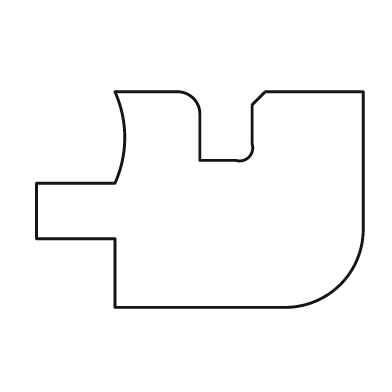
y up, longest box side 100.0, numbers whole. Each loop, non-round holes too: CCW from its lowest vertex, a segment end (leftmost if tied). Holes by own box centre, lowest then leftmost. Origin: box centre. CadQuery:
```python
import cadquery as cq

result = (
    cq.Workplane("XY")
    .moveTo(-26.0, -33.0)
    .lineTo(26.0, -33.0)
    .threePointArc((43.0, -26.0), (50.0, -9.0))
    .lineTo(50.0, 33.0)
    .lineTo(20.0, 33.0)
    .lineTo(16.0, 29.0)
    .lineTo(16.0, 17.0)
    .threePointArc((15.0, 13.0), (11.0, 12.0))
    .lineTo(0.0, 12.0)
    .lineTo(0.0, 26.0)
    .threePointArc((-2.0, 31.0), (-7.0, 33.0))
    .lineTo(-26.0, 33.0)
    .threePointArc((-23.0, 19.0), (-26.0, 5.0))
    .lineTo(-50.0, 5.0)
    .lineTo(-50.0, -12.0)
    .lineTo(-26.0, -12.0)
    .close()
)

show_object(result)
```